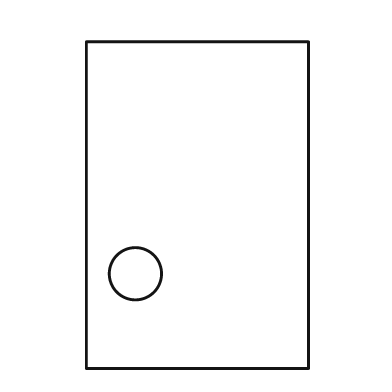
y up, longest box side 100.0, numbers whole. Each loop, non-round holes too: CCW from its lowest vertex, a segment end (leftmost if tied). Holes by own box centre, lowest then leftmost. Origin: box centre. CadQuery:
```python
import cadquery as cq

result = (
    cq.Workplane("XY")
    .moveTo(-34.0, -50.0)
    .lineTo(34.0, -50.0)
    .lineTo(34.0, 50.0)
    .lineTo(-34.0, 50.0)
    .close()
    .moveTo(-19.0, -21.0)
    .circle(8.0)
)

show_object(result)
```